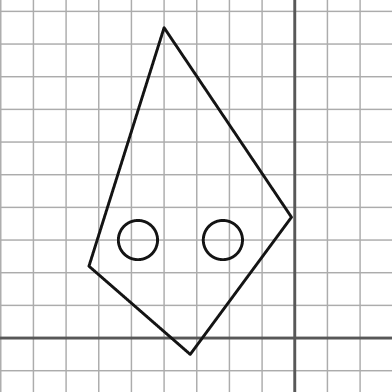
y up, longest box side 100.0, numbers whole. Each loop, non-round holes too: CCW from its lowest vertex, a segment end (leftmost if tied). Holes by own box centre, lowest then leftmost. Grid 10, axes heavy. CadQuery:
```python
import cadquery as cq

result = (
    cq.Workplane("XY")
    .moveTo(-32.0, -5.0)
    .lineTo(-1.0, 37.0)
    .lineTo(-40.0, 95.0)
    .lineTo(-63.0, 22.0)
    .close()
    .moveTo(-48.0, 30.0)
    .circle(6.0)
    .moveTo(-22.0, 30.0)
    .circle(6.0)
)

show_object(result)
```